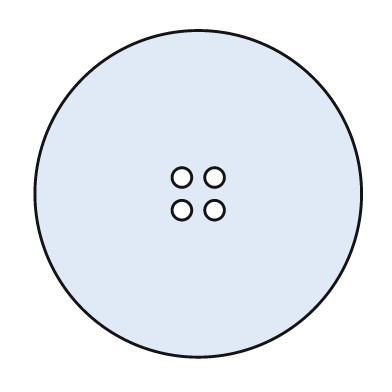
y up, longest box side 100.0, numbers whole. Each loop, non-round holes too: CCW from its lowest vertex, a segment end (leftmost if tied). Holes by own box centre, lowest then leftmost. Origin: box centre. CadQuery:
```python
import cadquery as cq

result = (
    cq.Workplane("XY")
    .moveTo(0.0, 0.0)
    .circle(50.0)
    .moveTo(-5.0, -5.0)
    .circle(3.0)
    .moveTo(5.0, -5.0)
    .circle(3.0)
    .moveTo(-5.0, 5.0)
    .circle(3.0)
    .moveTo(5.0, 5.0)
    .circle(3.0)
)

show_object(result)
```